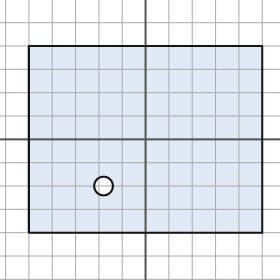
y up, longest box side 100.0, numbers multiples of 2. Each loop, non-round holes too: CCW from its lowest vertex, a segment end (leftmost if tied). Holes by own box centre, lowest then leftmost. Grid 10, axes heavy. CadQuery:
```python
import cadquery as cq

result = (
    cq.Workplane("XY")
    .moveTo(-50.0, -40.0)
    .lineTo(50.0, -40.0)
    .lineTo(50.0, 40.0)
    .lineTo(-50.0, 40.0)
    .close()
    .moveTo(-18.0, -20.0)
    .circle(4.0)
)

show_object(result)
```